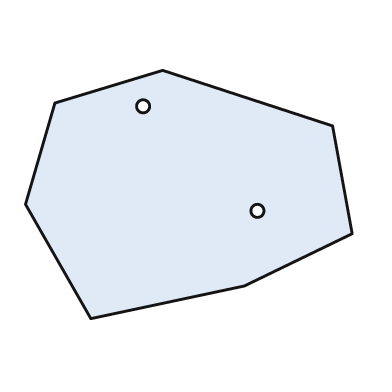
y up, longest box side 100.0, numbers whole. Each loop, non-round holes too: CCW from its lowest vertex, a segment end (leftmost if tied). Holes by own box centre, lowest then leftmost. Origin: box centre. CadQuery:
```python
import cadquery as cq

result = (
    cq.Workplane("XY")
    .moveTo(-30.0, -38.0)
    .lineTo(17.0, -28.0)
    .lineTo(50.0, -12.0)
    .lineTo(44.0, 21.0)
    .lineTo(-8.0, 38.0)
    .lineTo(-41.0, 28.0)
    .lineTo(-50.0, -3.0)
    .close()
    .moveTo(21.0, -5.0)
    .circle(2.0)
    .moveTo(-14.0, 27.0)
    .circle(2.0)
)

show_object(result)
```